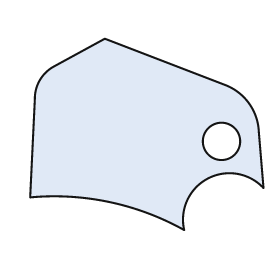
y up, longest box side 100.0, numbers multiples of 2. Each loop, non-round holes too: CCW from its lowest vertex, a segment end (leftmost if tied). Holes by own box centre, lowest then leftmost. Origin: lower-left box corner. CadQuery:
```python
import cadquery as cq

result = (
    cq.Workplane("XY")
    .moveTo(66.0, 0.0)
    .threePointArc((76.0, 22.0), (100.0, 18.0))
    .lineTo(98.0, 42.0)
    .threePointArc((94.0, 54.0), (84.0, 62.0))
    .lineTo(32.0, 82.0)
    .lineTo(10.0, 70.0)
    .threePointArc((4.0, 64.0), (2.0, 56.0))
    .lineTo(0.0, 14.0)
    .threePointArc((34.0, 12.0), (66.0, 0.0))
    .close()
    .moveTo(82.0, 38.0)
    .circle(8.0)
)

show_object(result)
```